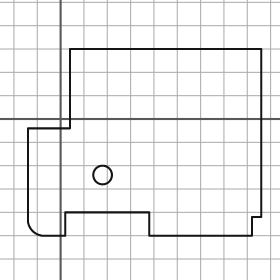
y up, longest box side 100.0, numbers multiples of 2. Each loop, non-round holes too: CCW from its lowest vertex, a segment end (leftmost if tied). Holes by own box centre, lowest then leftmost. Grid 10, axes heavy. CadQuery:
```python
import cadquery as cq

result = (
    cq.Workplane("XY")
    .moveTo(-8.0, -50.0)
    .lineTo(2.0, -50.0)
    .lineTo(2.0, -40.0)
    .lineTo(38.0, -40.0)
    .lineTo(38.0, -50.0)
    .lineTo(82.0, -50.0)
    .lineTo(82.0, -42.0)
    .lineTo(86.0, -42.0)
    .lineTo(86.0, 30.0)
    .lineTo(4.0, 30.0)
    .lineTo(4.0, -4.0)
    .lineTo(-14.0, -4.0)
    .lineTo(-14.0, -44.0)
    .threePointArc((-12.0, -48.0), (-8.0, -50.0))
    .close()
    .moveTo(18.0, -24.0)
    .circle(4.0)
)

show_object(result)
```